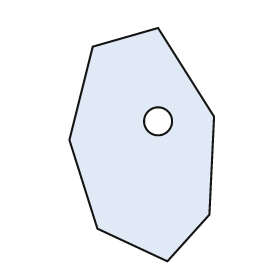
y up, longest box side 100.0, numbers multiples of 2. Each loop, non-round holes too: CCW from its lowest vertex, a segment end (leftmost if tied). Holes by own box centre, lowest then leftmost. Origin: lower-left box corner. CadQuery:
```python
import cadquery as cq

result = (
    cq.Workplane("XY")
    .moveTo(42.0, 0.0)
    .lineTo(60.0, 20.0)
    .lineTo(62.0, 62.0)
    .lineTo(38.0, 100.0)
    .lineTo(10.0, 92.0)
    .lineTo(0.0, 52.0)
    .lineTo(12.0, 14.0)
    .close()
    .moveTo(38.0, 60.0)
    .circle(6.0)
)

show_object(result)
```